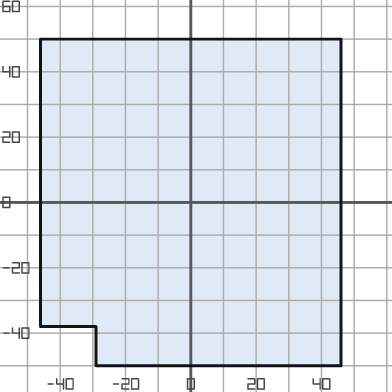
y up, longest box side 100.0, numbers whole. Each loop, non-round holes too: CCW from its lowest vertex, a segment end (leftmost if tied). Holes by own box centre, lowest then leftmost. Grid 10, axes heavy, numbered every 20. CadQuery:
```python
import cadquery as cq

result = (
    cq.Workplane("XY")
    .moveTo(-29.0, -50.0)
    .lineTo(46.0, -50.0)
    .lineTo(46.0, 50.0)
    .lineTo(-46.0, 50.0)
    .lineTo(-46.0, -38.0)
    .lineTo(-29.0, -38.0)
    .close()
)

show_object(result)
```